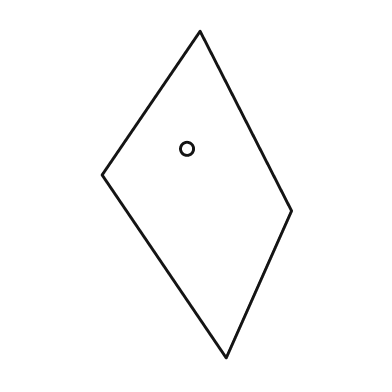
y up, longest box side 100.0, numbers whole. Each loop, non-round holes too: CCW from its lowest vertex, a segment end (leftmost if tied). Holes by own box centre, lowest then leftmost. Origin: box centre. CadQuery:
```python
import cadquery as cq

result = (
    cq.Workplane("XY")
    .moveTo(9.0, -50.0)
    .lineTo(29.0, -5.0)
    .lineTo(1.0, 50.0)
    .lineTo(-29.0, 6.0)
    .close()
    .moveTo(-3.0, 14.0)
    .circle(2.0)
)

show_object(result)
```